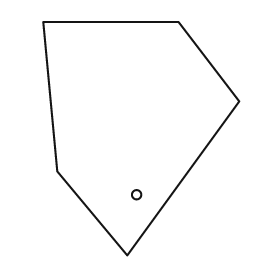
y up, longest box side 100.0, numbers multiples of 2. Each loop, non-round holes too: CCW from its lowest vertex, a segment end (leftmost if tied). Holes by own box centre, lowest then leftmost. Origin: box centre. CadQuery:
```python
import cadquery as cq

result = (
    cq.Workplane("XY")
    .moveTo(-6.0, -50.0)
    .lineTo(42.0, 16.0)
    .lineTo(16.0, 50.0)
    .lineTo(-42.0, 50.0)
    .lineTo(-36.0, -14.0)
    .close()
    .moveTo(-2.0, -24.0)
    .circle(2.0)
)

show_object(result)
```